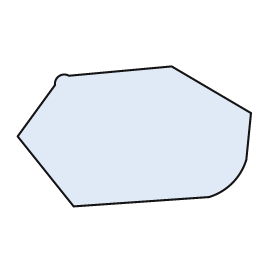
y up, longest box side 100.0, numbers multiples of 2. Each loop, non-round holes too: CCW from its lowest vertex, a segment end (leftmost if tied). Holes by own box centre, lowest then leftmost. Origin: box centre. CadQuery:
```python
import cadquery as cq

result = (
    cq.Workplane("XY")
    .moveTo(-26.0, -30.0)
    .lineTo(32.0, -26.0)
    .threePointArc((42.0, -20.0), (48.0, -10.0))
    .lineTo(50.0, 10.0)
    .lineTo(16.0, 30.0)
    .lineTo(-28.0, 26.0)
    .threePointArc((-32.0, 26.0), (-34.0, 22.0))
    .lineTo(-50.0, 0.0)
    .close()
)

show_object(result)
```